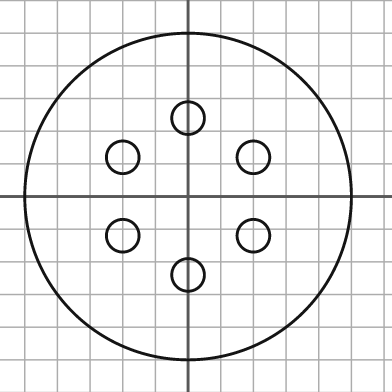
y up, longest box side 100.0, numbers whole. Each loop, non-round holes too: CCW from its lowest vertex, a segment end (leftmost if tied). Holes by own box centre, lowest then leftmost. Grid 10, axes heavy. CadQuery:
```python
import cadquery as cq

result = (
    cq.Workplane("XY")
    .moveTo(0.0, 0.0)
    .circle(50.0)
    .moveTo(0.0, -24.0)
    .circle(5.0)
    .moveTo(-20.0, -12.0)
    .circle(5.0)
    .moveTo(20.0, -12.0)
    .circle(5.0)
    .moveTo(-20.0, 12.0)
    .circle(5.0)
    .moveTo(20.0, 12.0)
    .circle(5.0)
    .moveTo(0.0, 24.0)
    .circle(5.0)
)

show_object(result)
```